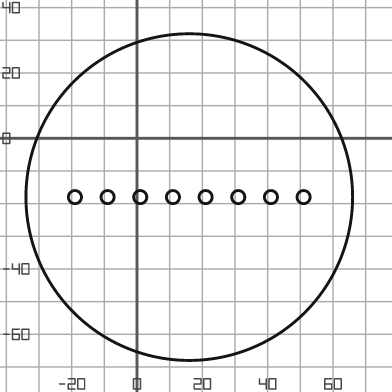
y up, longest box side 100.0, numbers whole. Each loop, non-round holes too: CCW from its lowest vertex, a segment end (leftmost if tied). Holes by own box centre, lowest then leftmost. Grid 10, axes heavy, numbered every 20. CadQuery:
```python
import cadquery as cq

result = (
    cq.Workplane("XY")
    .moveTo(16.0, -18.0)
    .circle(50.0)
    .moveTo(-19.0, -18.0)
    .circle(2.0)
    .moveTo(-9.0, -18.0)
    .circle(2.0)
    .moveTo(1.0, -18.0)
    .circle(2.0)
    .moveTo(11.0, -18.0)
    .circle(2.0)
    .moveTo(21.0, -18.0)
    .circle(2.0)
    .moveTo(31.0, -18.0)
    .circle(2.0)
    .moveTo(41.0, -18.0)
    .circle(2.0)
    .moveTo(51.0, -18.0)
    .circle(2.0)
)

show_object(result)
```